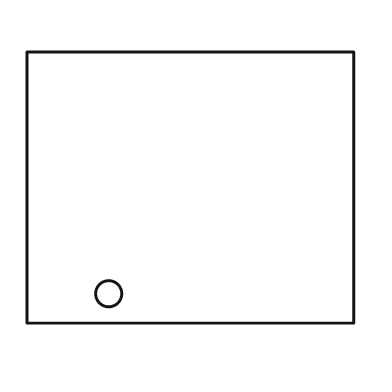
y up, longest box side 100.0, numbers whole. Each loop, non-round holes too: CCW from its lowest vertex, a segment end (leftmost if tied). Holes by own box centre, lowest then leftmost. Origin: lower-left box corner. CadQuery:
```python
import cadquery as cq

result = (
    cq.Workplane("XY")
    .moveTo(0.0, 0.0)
    .lineTo(100.0, 0.0)
    .lineTo(100.0, 83.0)
    .lineTo(0.0, 83.0)
    .close()
    .moveTo(25.0, 9.0)
    .circle(4.0)
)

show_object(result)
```